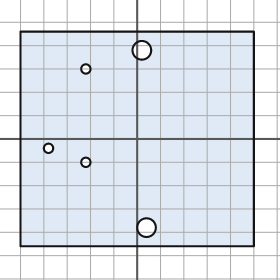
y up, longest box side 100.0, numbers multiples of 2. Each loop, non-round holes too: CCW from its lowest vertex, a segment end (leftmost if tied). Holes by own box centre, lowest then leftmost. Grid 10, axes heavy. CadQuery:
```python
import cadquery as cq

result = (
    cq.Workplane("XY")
    .moveTo(-50.0, -46.0)
    .lineTo(50.0, -46.0)
    .lineTo(50.0, 46.0)
    .lineTo(-50.0, 46.0)
    .close()
    .moveTo(4.0, -38.0)
    .circle(4.0)
    .moveTo(-22.0, -10.0)
    .circle(2.0)
    .moveTo(-38.0, -4.0)
    .circle(2.0)
    .moveTo(-22.0, 30.0)
    .circle(2.0)
    .moveTo(2.0, 38.0)
    .circle(4.0)
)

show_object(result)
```